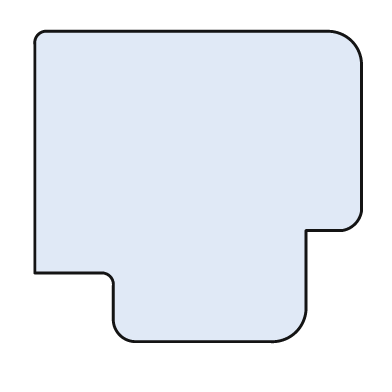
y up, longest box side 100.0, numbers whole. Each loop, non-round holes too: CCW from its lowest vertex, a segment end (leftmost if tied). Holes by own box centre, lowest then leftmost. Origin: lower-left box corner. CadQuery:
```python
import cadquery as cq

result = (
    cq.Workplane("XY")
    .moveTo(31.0, 0.0)
    .lineTo(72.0, 0.0)
    .threePointArc((80.0, 3.0), (83.0, 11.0))
    .lineTo(83.0, 34.0)
    .lineTo(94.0, 34.0)
    .threePointArc((98.0, 36.0), (100.0, 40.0))
    .lineTo(100.0, 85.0)
    .threePointArc((97.0, 92.0), (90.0, 95.0))
    .lineTo(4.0, 95.0)
    .threePointArc((1.0, 94.0), (0.0, 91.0))
    .lineTo(0.0, 21.0)
    .lineTo(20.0, 21.0)
    .threePointArc((23.0, 20.0), (24.0, 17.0))
    .lineTo(24.0, 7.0)
    .threePointArc((26.0, 2.0), (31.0, 0.0))
    .close()
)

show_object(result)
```